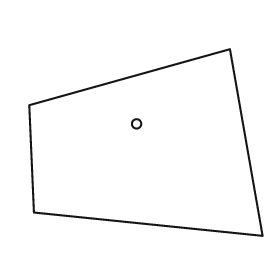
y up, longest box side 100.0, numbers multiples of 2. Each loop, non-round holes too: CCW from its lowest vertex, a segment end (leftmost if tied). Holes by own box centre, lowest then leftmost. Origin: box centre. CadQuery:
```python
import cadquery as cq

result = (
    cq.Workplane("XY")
    .moveTo(50.0, -40.0)
    .lineTo(36.0, 40.0)
    .lineTo(-50.0, 16.0)
    .lineTo(-48.0, -30.0)
    .close()
    .moveTo(-4.0, 8.0)
    .circle(2.0)
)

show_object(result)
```